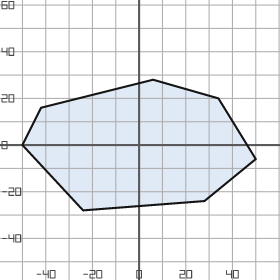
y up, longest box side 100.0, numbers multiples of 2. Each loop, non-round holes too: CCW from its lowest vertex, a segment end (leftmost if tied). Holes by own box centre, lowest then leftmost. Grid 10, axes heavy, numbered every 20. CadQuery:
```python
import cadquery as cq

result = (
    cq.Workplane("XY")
    .moveTo(-24.0, -28.0)
    .lineTo(28.0, -24.0)
    .lineTo(50.0, -6.0)
    .lineTo(34.0, 20.0)
    .lineTo(6.0, 28.0)
    .lineTo(-42.0, 16.0)
    .lineTo(-50.0, 0.0)
    .close()
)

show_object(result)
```